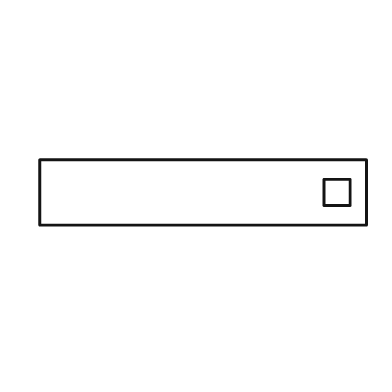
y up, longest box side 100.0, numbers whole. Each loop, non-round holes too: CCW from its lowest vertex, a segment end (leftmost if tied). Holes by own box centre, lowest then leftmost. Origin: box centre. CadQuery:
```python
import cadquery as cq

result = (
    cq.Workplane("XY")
    .moveTo(-50.0, -10.0)
    .lineTo(50.0, -10.0)
    .lineTo(50.0, 10.0)
    .lineTo(-50.0, 10.0)
    .close()
    .moveTo(37.0, -4.0)
    .lineTo(45.0, -4.0)
    .lineTo(45.0, 4.0)
    .lineTo(37.0, 4.0)
    .close()
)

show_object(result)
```